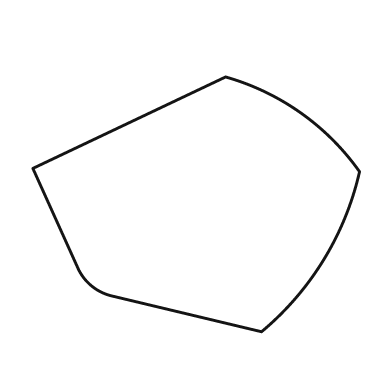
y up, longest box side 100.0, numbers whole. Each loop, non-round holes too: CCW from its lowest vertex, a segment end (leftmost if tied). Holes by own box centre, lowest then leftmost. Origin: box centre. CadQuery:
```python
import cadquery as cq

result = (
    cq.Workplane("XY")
    .moveTo(20.0, -39.0)
    .threePointArc((39.0, -17.0), (50.0, 10.0))
    .threePointArc((32.0, 28.0), (9.0, 39.0))
    .lineTo(-50.0, 11.0)
    .lineTo(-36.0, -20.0)
    .threePointArc((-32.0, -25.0), (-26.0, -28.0))
    .close()
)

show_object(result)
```